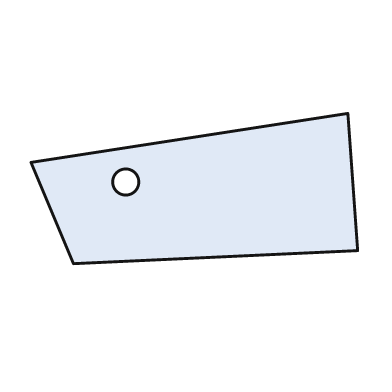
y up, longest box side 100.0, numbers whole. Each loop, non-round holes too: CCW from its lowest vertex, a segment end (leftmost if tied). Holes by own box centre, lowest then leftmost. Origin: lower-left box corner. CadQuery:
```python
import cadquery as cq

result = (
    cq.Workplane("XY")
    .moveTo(13.0, 0.0)
    .lineTo(100.0, 4.0)
    .lineTo(97.0, 46.0)
    .lineTo(0.0, 31.0)
    .close()
    .moveTo(29.0, 25.0)
    .circle(4.0)
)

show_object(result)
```